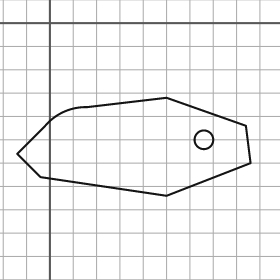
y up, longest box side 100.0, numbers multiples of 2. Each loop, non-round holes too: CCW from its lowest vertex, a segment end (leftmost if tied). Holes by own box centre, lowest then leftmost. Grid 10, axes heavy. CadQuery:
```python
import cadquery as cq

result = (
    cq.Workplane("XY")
    .moveTo(50.0, -74.0)
    .lineTo(86.0, -60.0)
    .lineTo(84.0, -44.0)
    .lineTo(50.0, -32.0)
    .lineTo(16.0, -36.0)
    .threePointArc((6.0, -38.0), (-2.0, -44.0))
    .lineTo(-14.0, -56.0)
    .lineTo(-4.0, -66.0)
    .close()
    .moveTo(66.0, -50.0)
    .circle(4.0)
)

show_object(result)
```